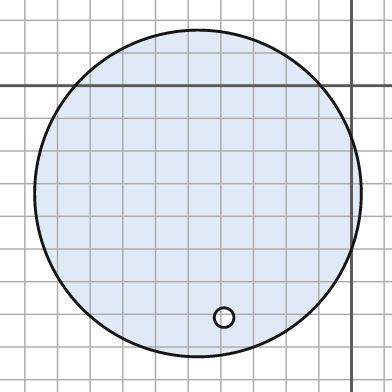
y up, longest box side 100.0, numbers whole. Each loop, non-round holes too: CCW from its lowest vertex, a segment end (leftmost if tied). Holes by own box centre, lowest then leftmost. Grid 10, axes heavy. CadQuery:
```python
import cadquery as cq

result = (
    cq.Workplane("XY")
    .moveTo(-47.0, -33.0)
    .circle(50.0)
    .moveTo(-39.0, -71.0)
    .circle(3.0)
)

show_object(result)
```